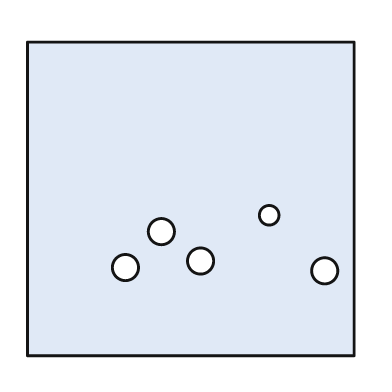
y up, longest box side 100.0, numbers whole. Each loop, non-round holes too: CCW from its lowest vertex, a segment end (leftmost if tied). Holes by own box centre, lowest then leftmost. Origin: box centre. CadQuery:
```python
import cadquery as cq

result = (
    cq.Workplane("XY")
    .moveTo(-50.0, -48.0)
    .lineTo(50.0, -48.0)
    .lineTo(50.0, 48.0)
    .lineTo(-50.0, 48.0)
    .close()
    .moveTo(41.0, -22.0)
    .circle(4.0)
    .moveTo(-20.0, -21.0)
    .circle(4.0)
    .moveTo(3.0, -19.0)
    .circle(4.0)
    .moveTo(-9.0, -10.0)
    .circle(4.0)
    .moveTo(24.0, -5.0)
    .circle(3.0)
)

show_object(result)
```